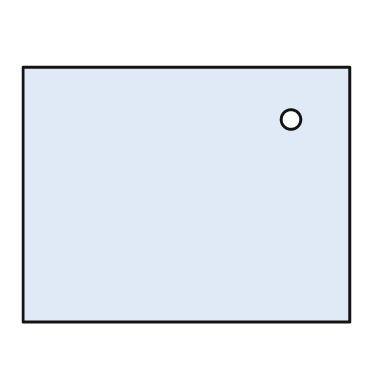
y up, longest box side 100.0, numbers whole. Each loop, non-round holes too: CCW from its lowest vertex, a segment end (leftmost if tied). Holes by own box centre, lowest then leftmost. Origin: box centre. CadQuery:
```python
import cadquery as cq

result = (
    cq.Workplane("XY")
    .moveTo(-50.0, -39.0)
    .lineTo(50.0, -39.0)
    .lineTo(50.0, 39.0)
    .lineTo(-50.0, 39.0)
    .close()
    .moveTo(32.0, 23.0)
    .circle(3.0)
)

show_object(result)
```